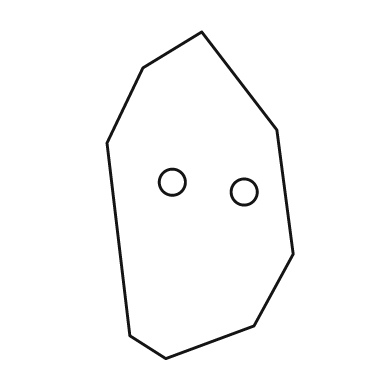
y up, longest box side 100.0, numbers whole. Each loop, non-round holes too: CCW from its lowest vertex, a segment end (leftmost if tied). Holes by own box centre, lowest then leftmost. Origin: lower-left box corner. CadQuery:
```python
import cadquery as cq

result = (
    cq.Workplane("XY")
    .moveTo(18.0, 0.0)
    .lineTo(45.0, 10.0)
    .lineTo(57.0, 32.0)
    .lineTo(52.0, 70.0)
    .lineTo(29.0, 100.0)
    .lineTo(11.0, 89.0)
    .lineTo(0.0, 66.0)
    .lineTo(7.0, 7.0)
    .close()
    .moveTo(42.0, 51.0)
    .circle(4.0)
    .moveTo(20.0, 54.0)
    .circle(4.0)
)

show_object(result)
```